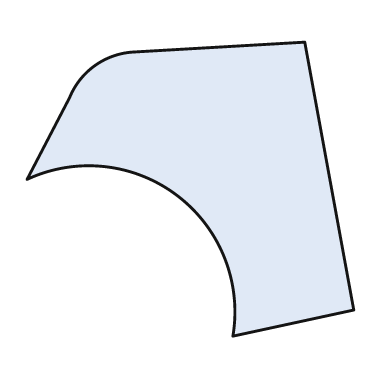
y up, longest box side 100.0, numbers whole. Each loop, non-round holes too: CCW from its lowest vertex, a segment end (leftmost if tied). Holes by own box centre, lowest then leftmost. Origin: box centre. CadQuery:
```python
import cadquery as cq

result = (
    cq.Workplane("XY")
    .moveTo(13.0, -45.0)
    .lineTo(50.0, -37.0)
    .lineTo(35.0, 45.0)
    .lineTo(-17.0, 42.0)
    .threePointArc((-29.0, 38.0), (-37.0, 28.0))
    .lineTo(-50.0, 3.0)
    .threePointArc((-4.0, -2.0), (13.0, -45.0))
    .close()
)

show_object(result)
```